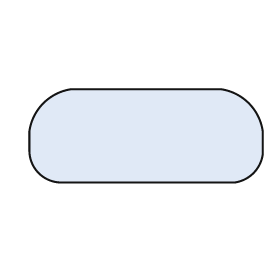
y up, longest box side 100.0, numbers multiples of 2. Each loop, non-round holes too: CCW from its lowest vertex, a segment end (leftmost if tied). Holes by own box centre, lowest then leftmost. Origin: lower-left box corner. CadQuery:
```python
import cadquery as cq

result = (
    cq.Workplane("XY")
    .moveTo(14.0, 0.0)
    .lineTo(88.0, 0.0)
    .threePointArc((96.0, 4.0), (100.0, 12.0))
    .lineTo(100.0, 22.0)
    .threePointArc((94.0, 34.0), (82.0, 40.0))
    .lineTo(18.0, 40.0)
    .threePointArc((6.0, 34.0), (0.0, 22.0))
    .lineTo(0.0, 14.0)
    .threePointArc((4.0, 4.0), (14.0, 0.0))
    .close()
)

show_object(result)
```